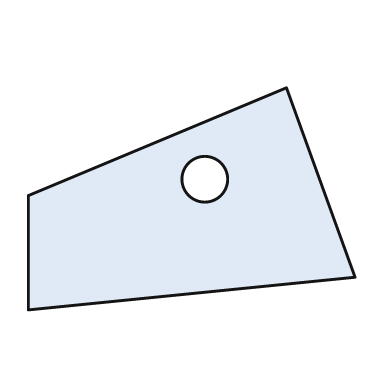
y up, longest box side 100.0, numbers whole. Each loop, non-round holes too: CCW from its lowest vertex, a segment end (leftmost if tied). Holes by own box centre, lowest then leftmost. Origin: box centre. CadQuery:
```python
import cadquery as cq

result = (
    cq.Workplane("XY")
    .moveTo(-50.0, -34.0)
    .lineTo(50.0, -24.0)
    .lineTo(29.0, 34.0)
    .lineTo(-50.0, 1.0)
    .close()
    .moveTo(4.0, 6.0)
    .circle(7.0)
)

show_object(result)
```